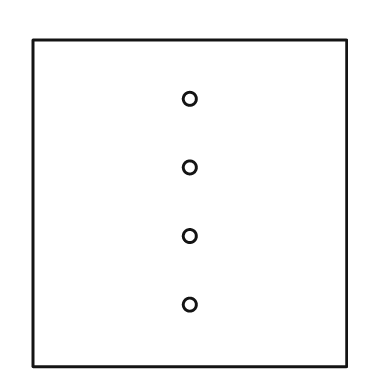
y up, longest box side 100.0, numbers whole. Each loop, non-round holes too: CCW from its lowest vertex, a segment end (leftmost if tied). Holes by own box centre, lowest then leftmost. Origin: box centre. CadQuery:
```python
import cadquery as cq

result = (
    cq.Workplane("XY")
    .moveTo(-48.0, -50.0)
    .lineTo(48.0, -50.0)
    .lineTo(48.0, 50.0)
    .lineTo(-48.0, 50.0)
    .close()
    .moveTo(0.0, -31.0)
    .circle(2.0)
    .moveTo(0.0, -10.0)
    .circle(2.0)
    .moveTo(0.0, 11.0)
    .circle(2.0)
    .moveTo(0.0, 32.0)
    .circle(2.0)
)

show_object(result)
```